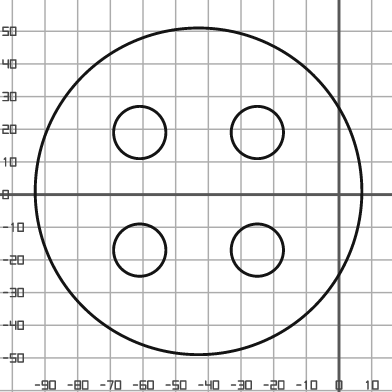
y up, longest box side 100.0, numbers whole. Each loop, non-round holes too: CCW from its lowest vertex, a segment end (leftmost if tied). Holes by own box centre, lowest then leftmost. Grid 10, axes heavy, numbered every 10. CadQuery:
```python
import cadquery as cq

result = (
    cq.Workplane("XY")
    .moveTo(-43.0, 1.0)
    .circle(50.0)
    .moveTo(-61.0, -17.0)
    .circle(8.0)
    .moveTo(-25.0, -17.0)
    .circle(8.0)
    .moveTo(-61.0, 19.0)
    .circle(8.0)
    .moveTo(-25.0, 19.0)
    .circle(8.0)
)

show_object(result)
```